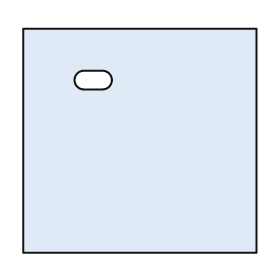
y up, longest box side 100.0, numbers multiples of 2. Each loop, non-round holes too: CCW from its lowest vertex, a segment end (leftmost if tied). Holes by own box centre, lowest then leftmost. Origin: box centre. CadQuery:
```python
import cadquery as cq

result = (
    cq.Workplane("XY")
    .moveTo(-50.0, -48.0)
    .lineTo(50.0, -48.0)
    .lineTo(50.0, 48.0)
    .lineTo(-50.0, 48.0)
    .close()
    .moveTo(-24.0, 22.0)
    .lineTo(-16.0, 22.0)
    .threePointArc((-12.0, 26.0), (-16.0, 30.0))
    .lineTo(-24.0, 30.0)
    .threePointArc((-28.0, 26.0), (-24.0, 22.0))
    .close()
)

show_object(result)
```